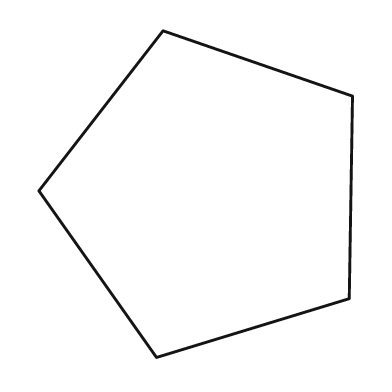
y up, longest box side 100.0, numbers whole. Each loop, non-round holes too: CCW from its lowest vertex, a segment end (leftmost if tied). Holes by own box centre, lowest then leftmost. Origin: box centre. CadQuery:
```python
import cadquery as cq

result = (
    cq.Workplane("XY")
    .moveTo(-12.0, -50.0)
    .lineTo(47.0, -32.0)
    .lineTo(48.0, 30.0)
    .lineTo(-10.0, 50.0)
    .lineTo(-48.0, 1.0)
    .close()
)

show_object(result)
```